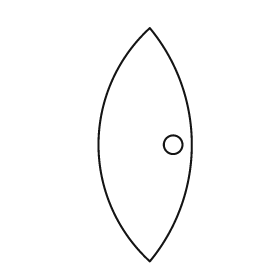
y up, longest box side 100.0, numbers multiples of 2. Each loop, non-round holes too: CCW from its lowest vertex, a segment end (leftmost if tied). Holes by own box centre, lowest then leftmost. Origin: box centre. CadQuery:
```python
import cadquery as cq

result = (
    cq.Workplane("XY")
    .moveTo(2.0, -50.0)
    .threePointArc((20.0, 0.0), (2.0, 50.0))
    .threePointArc((-20.0, 0.0), (2.0, -50.0))
    .close()
    .moveTo(12.0, 0.0)
    .circle(4.0)
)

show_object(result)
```